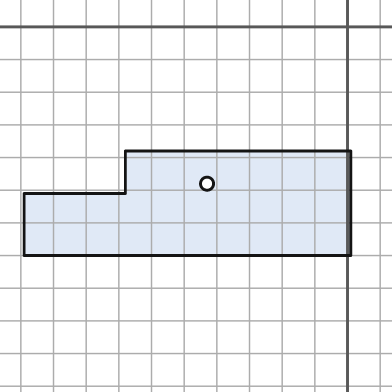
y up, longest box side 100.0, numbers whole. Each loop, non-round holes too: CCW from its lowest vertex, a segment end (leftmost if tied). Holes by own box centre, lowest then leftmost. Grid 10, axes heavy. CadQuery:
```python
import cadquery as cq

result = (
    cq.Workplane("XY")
    .moveTo(-99.0, -70.0)
    .lineTo(1.0, -70.0)
    .lineTo(1.0, -38.0)
    .lineTo(-68.0, -38.0)
    .lineTo(-68.0, -51.0)
    .lineTo(-99.0, -51.0)
    .close()
    .moveTo(-43.0, -48.0)
    .circle(2.0)
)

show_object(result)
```